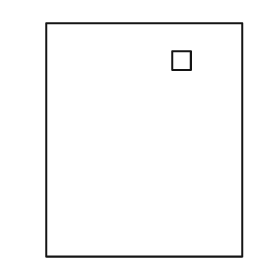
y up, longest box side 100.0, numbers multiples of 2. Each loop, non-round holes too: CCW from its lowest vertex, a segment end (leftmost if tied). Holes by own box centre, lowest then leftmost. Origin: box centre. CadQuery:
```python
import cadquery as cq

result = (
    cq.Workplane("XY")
    .moveTo(-42.0, -50.0)
    .lineTo(42.0, -50.0)
    .lineTo(42.0, 50.0)
    .lineTo(-42.0, 50.0)
    .close()
    .moveTo(12.0, 30.0)
    .lineTo(20.0, 30.0)
    .lineTo(20.0, 38.0)
    .lineTo(12.0, 38.0)
    .close()
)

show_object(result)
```